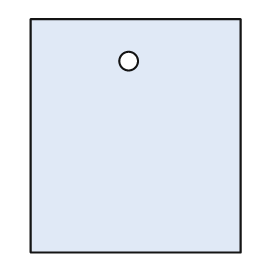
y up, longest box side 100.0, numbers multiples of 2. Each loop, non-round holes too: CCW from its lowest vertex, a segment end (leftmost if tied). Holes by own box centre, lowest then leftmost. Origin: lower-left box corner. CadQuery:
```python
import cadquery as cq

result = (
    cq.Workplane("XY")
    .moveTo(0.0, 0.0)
    .lineTo(90.0, 0.0)
    .lineTo(90.0, 100.0)
    .lineTo(0.0, 100.0)
    .close()
    .moveTo(42.0, 82.0)
    .circle(4.0)
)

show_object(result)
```